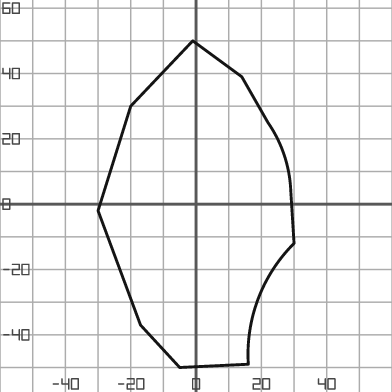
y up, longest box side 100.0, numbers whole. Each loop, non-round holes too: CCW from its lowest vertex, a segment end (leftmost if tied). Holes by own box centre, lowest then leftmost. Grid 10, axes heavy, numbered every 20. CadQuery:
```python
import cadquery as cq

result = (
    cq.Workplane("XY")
    .moveTo(-5.0, -50.0)
    .lineTo(16.0, -49.0)
    .threePointArc((19.0, -29.0), (30.0, -12.0))
    .lineTo(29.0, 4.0)
    .threePointArc((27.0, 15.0), (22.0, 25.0))
    .lineTo(14.0, 39.0)
    .lineTo(-1.0, 50.0)
    .lineTo(-20.0, 30.0)
    .lineTo(-30.0, -2.0)
    .lineTo(-17.0, -37.0)
    .close()
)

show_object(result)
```